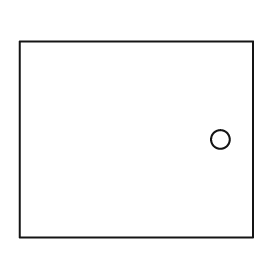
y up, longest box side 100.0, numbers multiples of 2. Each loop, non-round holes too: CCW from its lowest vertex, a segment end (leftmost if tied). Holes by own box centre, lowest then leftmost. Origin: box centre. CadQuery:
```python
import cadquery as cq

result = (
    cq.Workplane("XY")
    .moveTo(-50.0, -42.0)
    .lineTo(50.0, -42.0)
    .lineTo(50.0, 42.0)
    .lineTo(-50.0, 42.0)
    .close()
    .moveTo(36.0, 0.0)
    .circle(4.0)
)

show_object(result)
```